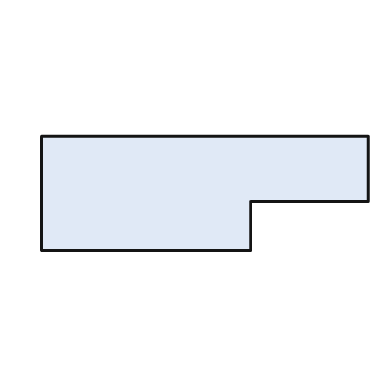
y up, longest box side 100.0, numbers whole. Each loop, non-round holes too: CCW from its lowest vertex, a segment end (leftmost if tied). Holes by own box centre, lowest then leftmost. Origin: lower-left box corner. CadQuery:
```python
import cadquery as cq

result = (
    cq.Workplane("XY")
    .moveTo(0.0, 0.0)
    .lineTo(64.0, 0.0)
    .lineTo(64.0, 15.0)
    .lineTo(100.0, 15.0)
    .lineTo(100.0, 35.0)
    .lineTo(0.0, 35.0)
    .close()
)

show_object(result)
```